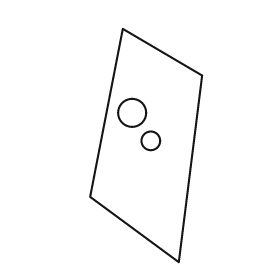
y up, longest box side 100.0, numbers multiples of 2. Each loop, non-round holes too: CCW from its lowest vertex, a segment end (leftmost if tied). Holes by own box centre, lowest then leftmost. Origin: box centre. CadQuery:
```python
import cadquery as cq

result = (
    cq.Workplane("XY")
    .moveTo(14.0, -50.0)
    .lineTo(24.0, 30.0)
    .lineTo(-10.0, 50.0)
    .lineTo(-24.0, -22.0)
    .close()
    .moveTo(2.0, 2.0)
    .circle(4.0)
    .moveTo(-6.0, 14.0)
    .circle(6.0)
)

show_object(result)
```